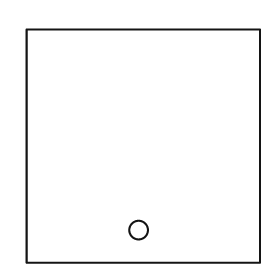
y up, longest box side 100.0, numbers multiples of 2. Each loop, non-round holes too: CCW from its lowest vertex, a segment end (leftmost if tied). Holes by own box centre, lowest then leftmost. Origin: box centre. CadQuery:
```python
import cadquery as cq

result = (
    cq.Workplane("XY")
    .moveTo(-50.0, -50.0)
    .lineTo(50.0, -50.0)
    .lineTo(50.0, 50.0)
    .lineTo(-50.0, 50.0)
    .close()
    .moveTo(-2.0, -36.0)
    .circle(4.0)
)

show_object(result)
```